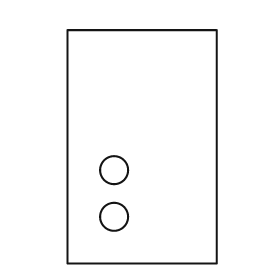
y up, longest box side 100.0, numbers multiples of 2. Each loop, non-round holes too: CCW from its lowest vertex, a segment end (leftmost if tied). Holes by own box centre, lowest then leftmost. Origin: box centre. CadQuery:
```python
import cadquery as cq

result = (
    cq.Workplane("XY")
    .moveTo(-32.0, -50.0)
    .lineTo(32.0, -50.0)
    .lineTo(32.0, 50.0)
    .lineTo(-32.0, 50.0)
    .close()
    .moveTo(-12.0, -30.0)
    .circle(6.0)
    .moveTo(-12.0, -10.0)
    .circle(6.0)
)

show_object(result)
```